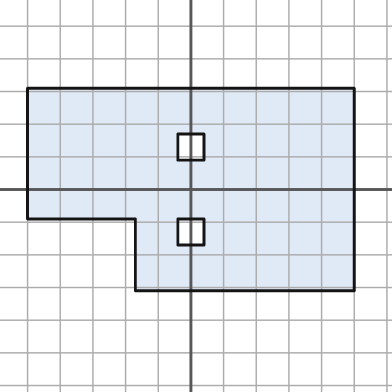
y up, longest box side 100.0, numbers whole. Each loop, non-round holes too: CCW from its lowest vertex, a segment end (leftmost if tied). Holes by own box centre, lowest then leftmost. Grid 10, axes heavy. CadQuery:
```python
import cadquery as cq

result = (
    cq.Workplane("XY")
    .moveTo(-17.0, -31.0)
    .lineTo(50.0, -31.0)
    .lineTo(50.0, 31.0)
    .lineTo(-50.0, 31.0)
    .lineTo(-50.0, -9.0)
    .lineTo(-17.0, -9.0)
    .close()
    .moveTo(-4.0, -17.0)
    .lineTo(4.0, -17.0)
    .lineTo(4.0, -9.0)
    .lineTo(-4.0, -9.0)
    .close()
    .moveTo(-4.0, 9.0)
    .lineTo(4.0, 9.0)
    .lineTo(4.0, 17.0)
    .lineTo(-4.0, 17.0)
    .close()
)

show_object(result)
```